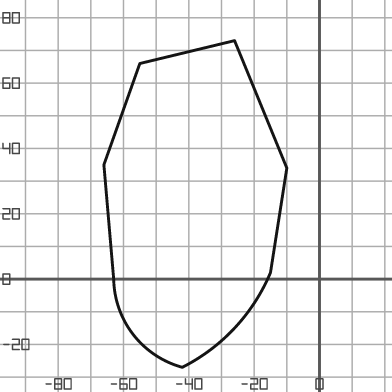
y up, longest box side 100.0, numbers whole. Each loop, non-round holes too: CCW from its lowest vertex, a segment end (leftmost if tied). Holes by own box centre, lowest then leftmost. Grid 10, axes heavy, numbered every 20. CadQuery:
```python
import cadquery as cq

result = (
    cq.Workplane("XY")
    .moveTo(-42.0, -27.0)
    .threePointArc((-26.0, -15.0), (-15.0, 2.0))
    .lineTo(-10.0, 34.0)
    .lineTo(-26.0, 73.0)
    .lineTo(-55.0, 66.0)
    .lineTo(-66.0, 35.0)
    .lineTo(-63.0, 0.0)
    .threePointArc((-57.0, -17.0), (-42.0, -27.0))
    .close()
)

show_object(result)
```